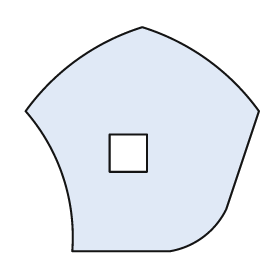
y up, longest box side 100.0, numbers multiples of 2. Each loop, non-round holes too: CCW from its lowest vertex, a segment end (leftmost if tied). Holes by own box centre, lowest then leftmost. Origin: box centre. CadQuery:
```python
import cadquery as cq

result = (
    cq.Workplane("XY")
    .moveTo(-30.0, -48.0)
    .lineTo(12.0, -48.0)
    .threePointArc((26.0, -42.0), (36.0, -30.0))
    .lineTo(50.0, 12.0)
    .threePointArc((28.0, 34.0), (0.0, 48.0))
    .threePointArc((-28.0, 34.0), (-50.0, 12.0))
    .threePointArc((-34.0, -16.0), (-30.0, -48.0))
    .close()
    .moveTo(-14.0, -14.0)
    .lineTo(2.0, -14.0)
    .lineTo(2.0, 2.0)
    .lineTo(-14.0, 2.0)
    .close()
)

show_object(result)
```